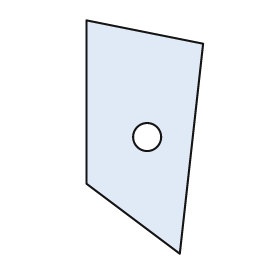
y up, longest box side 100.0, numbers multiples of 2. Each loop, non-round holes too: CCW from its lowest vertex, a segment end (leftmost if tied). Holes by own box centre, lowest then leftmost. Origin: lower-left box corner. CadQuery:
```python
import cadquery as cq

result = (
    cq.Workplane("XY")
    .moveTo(40.0, 0.0)
    .lineTo(50.0, 90.0)
    .lineTo(0.0, 100.0)
    .lineTo(0.0, 30.0)
    .close()
    .moveTo(26.0, 50.0)
    .circle(6.0)
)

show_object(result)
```